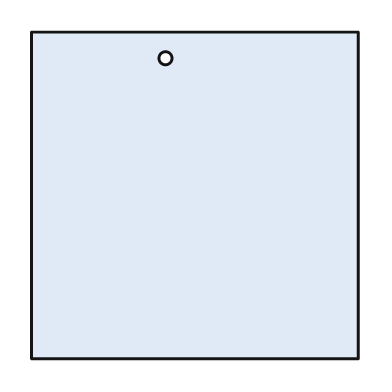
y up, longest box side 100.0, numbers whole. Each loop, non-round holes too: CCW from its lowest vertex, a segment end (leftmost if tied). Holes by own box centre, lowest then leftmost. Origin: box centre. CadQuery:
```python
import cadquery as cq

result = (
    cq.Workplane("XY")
    .moveTo(-50.0, -50.0)
    .lineTo(50.0, -50.0)
    .lineTo(50.0, 50.0)
    .lineTo(-50.0, 50.0)
    .close()
    .moveTo(-9.0, 42.0)
    .circle(2.0)
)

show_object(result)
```